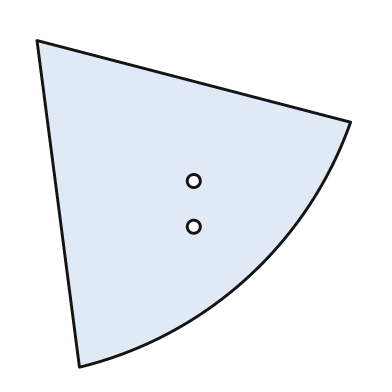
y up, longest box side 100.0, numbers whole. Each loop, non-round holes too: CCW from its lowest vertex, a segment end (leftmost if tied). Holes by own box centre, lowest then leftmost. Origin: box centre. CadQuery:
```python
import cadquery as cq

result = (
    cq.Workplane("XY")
    .moveTo(-35.0, -50.0)
    .threePointArc((16.0, -23.0), (48.0, 25.0))
    .lineTo(-48.0, 50.0)
    .close()
    .moveTo(0.0, -7.0)
    .circle(2.0)
    .moveTo(0.0, 7.0)
    .circle(2.0)
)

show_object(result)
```